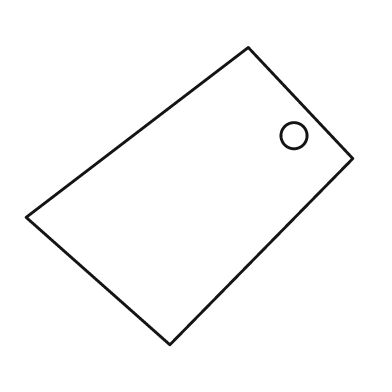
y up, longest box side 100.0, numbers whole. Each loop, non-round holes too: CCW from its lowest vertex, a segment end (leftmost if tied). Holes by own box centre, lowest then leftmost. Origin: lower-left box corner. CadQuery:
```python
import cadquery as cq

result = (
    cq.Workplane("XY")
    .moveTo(44.0, 0.0)
    .lineTo(100.0, 57.0)
    .lineTo(68.0, 91.0)
    .lineTo(0.0, 39.0)
    .close()
    .moveTo(82.0, 64.0)
    .circle(4.0)
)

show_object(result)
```